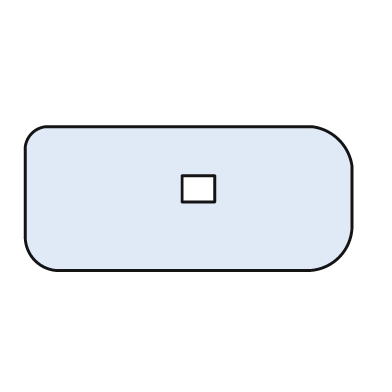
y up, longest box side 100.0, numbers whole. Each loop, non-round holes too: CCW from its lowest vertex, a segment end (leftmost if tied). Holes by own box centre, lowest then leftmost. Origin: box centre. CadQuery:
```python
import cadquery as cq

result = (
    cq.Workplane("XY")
    .moveTo(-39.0, -22.0)
    .lineTo(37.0, -22.0)
    .threePointArc((46.0, -18.0), (50.0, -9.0))
    .lineTo(50.0, 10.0)
    .threePointArc((46.0, 18.0), (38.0, 22.0))
    .lineTo(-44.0, 22.0)
    .threePointArc((-48.0, 20.0), (-50.0, 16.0))
    .lineTo(-50.0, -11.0)
    .threePointArc((-47.0, -19.0), (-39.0, -22.0))
    .close()
    .moveTo(-2.0, -1.0)
    .lineTo(8.0, -1.0)
    .lineTo(8.0, 7.0)
    .lineTo(-2.0, 7.0)
    .close()
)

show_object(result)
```